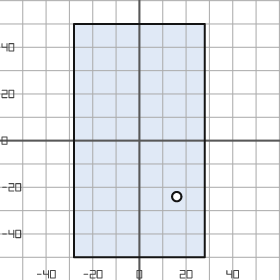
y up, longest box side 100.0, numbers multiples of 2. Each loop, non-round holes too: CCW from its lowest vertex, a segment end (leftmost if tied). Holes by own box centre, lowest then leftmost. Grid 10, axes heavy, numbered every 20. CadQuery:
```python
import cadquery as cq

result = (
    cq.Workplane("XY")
    .moveTo(-28.0, -50.0)
    .lineTo(28.0, -50.0)
    .lineTo(28.0, 50.0)
    .lineTo(-28.0, 50.0)
    .close()
    .moveTo(16.0, -24.0)
    .circle(2.0)
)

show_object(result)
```